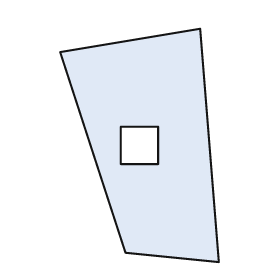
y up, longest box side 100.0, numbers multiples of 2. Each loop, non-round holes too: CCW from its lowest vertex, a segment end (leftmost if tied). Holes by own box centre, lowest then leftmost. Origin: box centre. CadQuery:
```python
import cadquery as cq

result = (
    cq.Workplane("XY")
    .moveTo(34.0, -50.0)
    .lineTo(26.0, 50.0)
    .lineTo(-34.0, 40.0)
    .lineTo(-6.0, -46.0)
    .close()
    .moveTo(-8.0, -8.0)
    .lineTo(8.0, -8.0)
    .lineTo(8.0, 8.0)
    .lineTo(-8.0, 8.0)
    .close()
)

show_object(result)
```